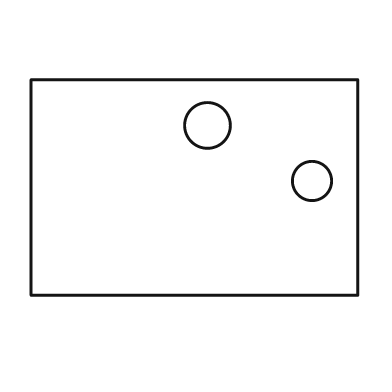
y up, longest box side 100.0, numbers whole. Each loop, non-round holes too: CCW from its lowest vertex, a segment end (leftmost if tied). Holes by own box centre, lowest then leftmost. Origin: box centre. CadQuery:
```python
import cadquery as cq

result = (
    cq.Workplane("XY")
    .moveTo(-50.0, -33.0)
    .lineTo(50.0, -33.0)
    .lineTo(50.0, 33.0)
    .lineTo(-50.0, 33.0)
    .close()
    .moveTo(36.0, 2.0)
    .circle(6.0)
    .moveTo(4.0, 19.0)
    .circle(7.0)
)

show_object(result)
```